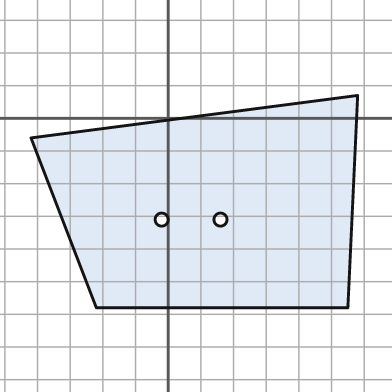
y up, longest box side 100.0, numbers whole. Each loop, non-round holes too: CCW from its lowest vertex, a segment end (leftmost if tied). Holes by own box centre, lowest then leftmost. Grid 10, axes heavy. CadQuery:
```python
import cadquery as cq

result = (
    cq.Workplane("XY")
    .moveTo(-22.0, -58.0)
    .lineTo(55.0, -58.0)
    .lineTo(58.0, 7.0)
    .lineTo(-42.0, -6.0)
    .close()
    .moveTo(-2.0, -31.0)
    .circle(2.0)
    .moveTo(16.0, -31.0)
    .circle(2.0)
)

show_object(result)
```